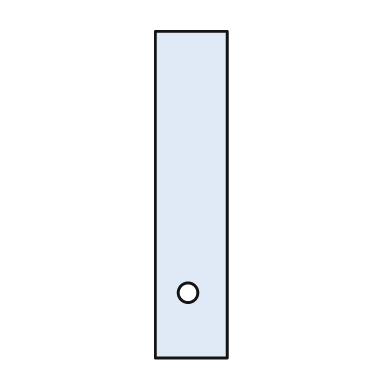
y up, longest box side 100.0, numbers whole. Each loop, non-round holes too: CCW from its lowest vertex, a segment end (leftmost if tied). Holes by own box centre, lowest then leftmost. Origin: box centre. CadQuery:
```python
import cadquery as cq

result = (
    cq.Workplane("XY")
    .moveTo(-11.0, -50.0)
    .lineTo(11.0, -50.0)
    .lineTo(11.0, 50.0)
    .lineTo(-11.0, 50.0)
    .close()
    .moveTo(-1.0, -30.0)
    .circle(3.0)
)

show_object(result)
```